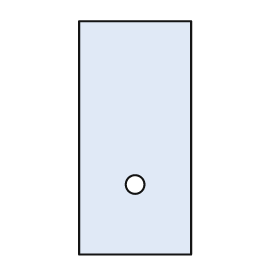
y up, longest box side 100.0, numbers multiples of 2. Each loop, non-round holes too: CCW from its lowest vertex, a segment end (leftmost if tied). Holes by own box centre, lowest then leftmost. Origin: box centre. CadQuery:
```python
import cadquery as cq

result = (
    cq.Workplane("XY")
    .moveTo(-24.0, -50.0)
    .lineTo(24.0, -50.0)
    .lineTo(24.0, 50.0)
    .lineTo(-24.0, 50.0)
    .close()
    .moveTo(0.0, -20.0)
    .circle(4.0)
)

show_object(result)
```